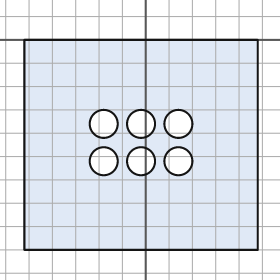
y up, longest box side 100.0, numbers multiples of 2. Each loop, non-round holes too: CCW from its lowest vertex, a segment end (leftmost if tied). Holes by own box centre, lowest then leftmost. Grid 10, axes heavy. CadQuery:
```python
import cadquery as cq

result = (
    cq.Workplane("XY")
    .moveTo(-52.0, -90.0)
    .lineTo(48.0, -90.0)
    .lineTo(48.0, 0.0)
    .lineTo(-52.0, 0.0)
    .close()
    .moveTo(-18.0, -52.0)
    .circle(6.0)
    .moveTo(-2.0, -52.0)
    .circle(6.0)
    .moveTo(14.0, -52.0)
    .circle(6.0)
    .moveTo(-18.0, -36.0)
    .circle(6.0)
    .moveTo(-2.0, -36.0)
    .circle(6.0)
    .moveTo(14.0, -36.0)
    .circle(6.0)
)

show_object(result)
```